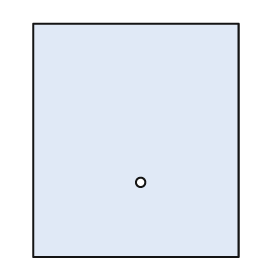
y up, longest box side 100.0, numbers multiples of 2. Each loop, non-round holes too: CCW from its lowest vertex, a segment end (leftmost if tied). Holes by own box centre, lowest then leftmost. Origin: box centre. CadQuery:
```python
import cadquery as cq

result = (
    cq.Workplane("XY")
    .moveTo(-44.0, -50.0)
    .lineTo(44.0, -50.0)
    .lineTo(44.0, 50.0)
    .lineTo(-44.0, 50.0)
    .close()
    .moveTo(2.0, -18.0)
    .circle(2.0)
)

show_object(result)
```